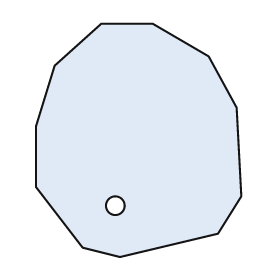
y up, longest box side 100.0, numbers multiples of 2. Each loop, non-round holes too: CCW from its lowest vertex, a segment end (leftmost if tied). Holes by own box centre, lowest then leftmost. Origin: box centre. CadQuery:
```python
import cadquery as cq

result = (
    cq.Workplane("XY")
    .moveTo(-8.0, -50.0)
    .lineTo(34.0, -40.0)
    .lineTo(44.0, -24.0)
    .lineTo(42.0, 14.0)
    .lineTo(30.0, 36.0)
    .lineTo(6.0, 50.0)
    .lineTo(-16.0, 50.0)
    .lineTo(-36.0, 32.0)
    .lineTo(-44.0, 6.0)
    .lineTo(-44.0, -20.0)
    .lineTo(-24.0, -46.0)
    .close()
    .moveTo(-10.0, -28.0)
    .circle(4.0)
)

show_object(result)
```